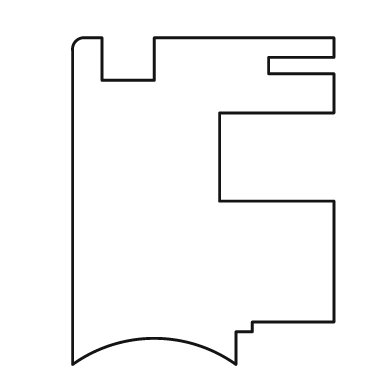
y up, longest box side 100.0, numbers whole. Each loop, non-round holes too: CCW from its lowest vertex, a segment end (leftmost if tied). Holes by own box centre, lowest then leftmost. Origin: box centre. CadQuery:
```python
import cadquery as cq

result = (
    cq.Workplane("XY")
    .moveTo(-40.0, -50.0)
    .threePointArc((-15.0, -42.0), (10.0, -50.0))
    .lineTo(10.0, -40.0)
    .lineTo(15.0, -40.0)
    .lineTo(15.0, -37.0)
    .lineTo(40.0, -37.0)
    .lineTo(40.0, 0.0)
    .lineTo(5.0, 0.0)
    .lineTo(5.0, 27.0)
    .lineTo(40.0, 27.0)
    .lineTo(40.0, 39.0)
    .lineTo(20.0, 39.0)
    .lineTo(20.0, 44.0)
    .lineTo(40.0, 44.0)
    .lineTo(40.0, 50.0)
    .lineTo(-15.0, 50.0)
    .lineTo(-15.0, 37.0)
    .lineTo(-31.0, 37.0)
    .lineTo(-31.0, 50.0)
    .lineTo(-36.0, 50.0)
    .threePointArc((-39.0, 49.0), (-40.0, 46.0))
    .close()
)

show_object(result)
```